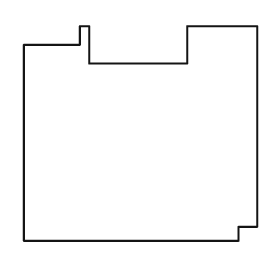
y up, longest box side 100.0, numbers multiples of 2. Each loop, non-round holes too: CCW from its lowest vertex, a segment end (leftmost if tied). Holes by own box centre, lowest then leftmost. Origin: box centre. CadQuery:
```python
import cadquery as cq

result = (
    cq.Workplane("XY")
    .moveTo(-50.0, -46.0)
    .lineTo(42.0, -46.0)
    .lineTo(42.0, -40.0)
    .lineTo(50.0, -40.0)
    .lineTo(50.0, 46.0)
    .lineTo(20.0, 46.0)
    .lineTo(20.0, 30.0)
    .lineTo(-22.0, 30.0)
    .lineTo(-22.0, 46.0)
    .lineTo(-26.0, 46.0)
    .lineTo(-26.0, 38.0)
    .lineTo(-50.0, 38.0)
    .close()
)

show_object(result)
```